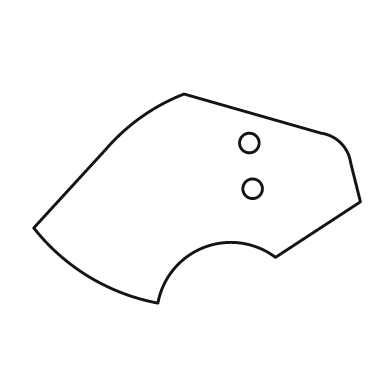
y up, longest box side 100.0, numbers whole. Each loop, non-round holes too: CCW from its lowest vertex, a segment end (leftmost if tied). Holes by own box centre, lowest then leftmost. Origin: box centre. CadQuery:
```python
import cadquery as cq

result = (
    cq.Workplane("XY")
    .moveTo(-12.0, -32.0)
    .threePointArc((2.0, -15.0), (24.0, -18.0))
    .lineTo(50.0, -1.0)
    .lineTo(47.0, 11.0)
    .threePointArc((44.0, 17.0), (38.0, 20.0))
    .lineTo(-4.0, 32.0)
    .threePointArc((-17.0, 25.0), (-28.0, 15.0))
    .lineTo(-50.0, -9.0)
    .threePointArc((-33.0, -24.0), (-12.0, -32.0))
    .close()
    .moveTo(17.0, 3.0)
    .circle(3.0)
    .moveTo(16.0, 17.0)
    .circle(3.0)
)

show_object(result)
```